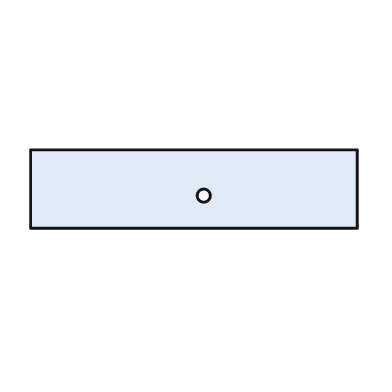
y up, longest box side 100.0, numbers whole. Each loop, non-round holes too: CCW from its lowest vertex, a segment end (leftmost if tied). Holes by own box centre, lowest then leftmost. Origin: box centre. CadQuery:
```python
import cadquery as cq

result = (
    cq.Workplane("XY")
    .moveTo(-50.0, -12.0)
    .lineTo(50.0, -12.0)
    .lineTo(50.0, 12.0)
    .lineTo(-50.0, 12.0)
    .close()
    .moveTo(3.0, -2.0)
    .circle(2.0)
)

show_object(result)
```